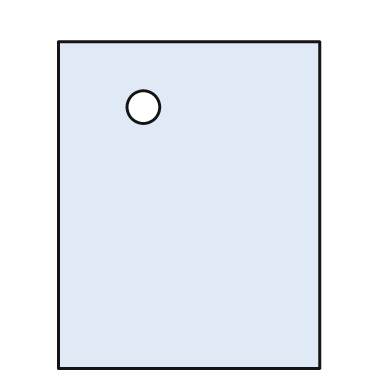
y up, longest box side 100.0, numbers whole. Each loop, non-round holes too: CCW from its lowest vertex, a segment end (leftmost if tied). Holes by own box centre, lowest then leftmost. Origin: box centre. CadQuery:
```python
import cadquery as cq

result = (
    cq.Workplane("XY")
    .moveTo(-40.0, -50.0)
    .lineTo(40.0, -50.0)
    .lineTo(40.0, 50.0)
    .lineTo(-40.0, 50.0)
    .close()
    .moveTo(-14.0, 30.0)
    .circle(5.0)
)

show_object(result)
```